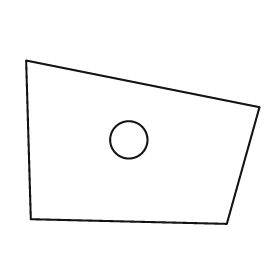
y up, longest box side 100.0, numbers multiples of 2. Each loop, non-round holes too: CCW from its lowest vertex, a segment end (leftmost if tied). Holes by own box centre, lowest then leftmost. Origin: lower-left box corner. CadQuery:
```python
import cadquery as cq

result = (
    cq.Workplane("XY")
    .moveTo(86.0, 0.0)
    .lineTo(100.0, 50.0)
    .lineTo(0.0, 70.0)
    .lineTo(2.0, 2.0)
    .close()
    .moveTo(44.0, 36.0)
    .circle(8.0)
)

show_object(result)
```